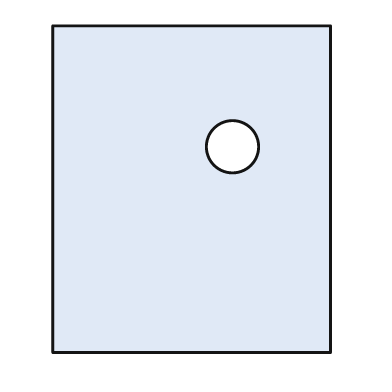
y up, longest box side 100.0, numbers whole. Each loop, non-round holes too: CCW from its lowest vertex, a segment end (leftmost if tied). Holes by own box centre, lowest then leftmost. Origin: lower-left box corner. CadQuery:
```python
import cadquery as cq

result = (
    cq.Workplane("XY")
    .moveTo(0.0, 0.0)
    .lineTo(85.0, 0.0)
    .lineTo(85.0, 100.0)
    .lineTo(0.0, 100.0)
    .close()
    .moveTo(55.0, 63.0)
    .circle(8.0)
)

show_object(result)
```